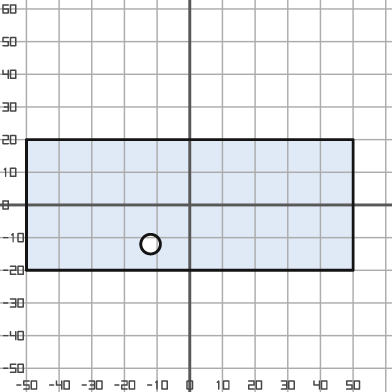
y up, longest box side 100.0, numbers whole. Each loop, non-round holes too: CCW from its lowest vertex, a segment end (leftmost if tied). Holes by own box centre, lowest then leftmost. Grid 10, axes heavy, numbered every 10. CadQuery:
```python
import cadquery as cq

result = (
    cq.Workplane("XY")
    .moveTo(-50.0, -20.0)
    .lineTo(50.0, -20.0)
    .lineTo(50.0, 20.0)
    .lineTo(-50.0, 20.0)
    .close()
    .moveTo(-12.0, -12.0)
    .circle(3.0)
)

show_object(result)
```